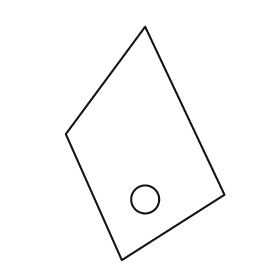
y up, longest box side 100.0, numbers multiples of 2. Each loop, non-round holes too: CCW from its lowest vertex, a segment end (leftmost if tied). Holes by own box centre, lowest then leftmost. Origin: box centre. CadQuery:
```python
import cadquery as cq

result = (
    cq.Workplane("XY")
    .moveTo(-10.0, -50.0)
    .lineTo(34.0, -22.0)
    .lineTo(0.0, 50.0)
    .lineTo(-34.0, 4.0)
    .close()
    .moveTo(0.0, -24.0)
    .circle(6.0)
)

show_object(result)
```